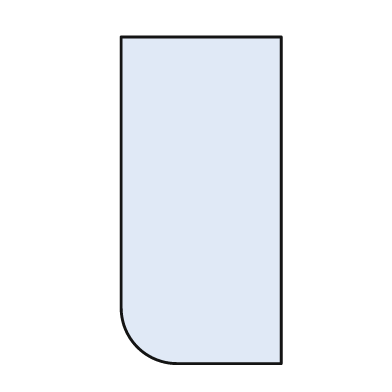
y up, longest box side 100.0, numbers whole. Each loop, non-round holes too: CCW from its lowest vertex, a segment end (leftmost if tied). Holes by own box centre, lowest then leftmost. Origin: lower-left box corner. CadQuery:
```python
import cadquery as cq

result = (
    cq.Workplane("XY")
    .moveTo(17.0, 0.0)
    .lineTo(49.0, 0.0)
    .lineTo(49.0, 100.0)
    .lineTo(0.0, 100.0)
    .lineTo(0.0, 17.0)
    .threePointArc((5.0, 5.0), (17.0, 0.0))
    .close()
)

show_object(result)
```